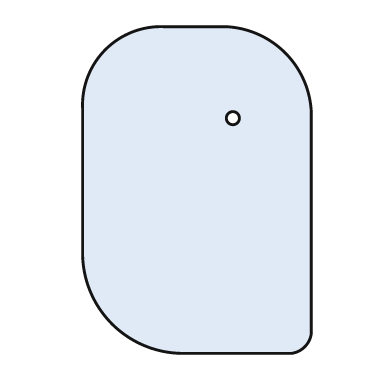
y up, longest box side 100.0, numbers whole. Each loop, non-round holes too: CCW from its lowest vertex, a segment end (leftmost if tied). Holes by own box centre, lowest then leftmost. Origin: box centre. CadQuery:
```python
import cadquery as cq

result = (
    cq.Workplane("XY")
    .moveTo(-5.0, -50.0)
    .lineTo(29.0, -50.0)
    .threePointArc((33.0, -48.0), (35.0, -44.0))
    .lineTo(35.0, 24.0)
    .threePointArc((27.0, 42.0), (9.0, 50.0))
    .lineTo(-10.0, 50.0)
    .threePointArc((-28.0, 43.0), (-35.0, 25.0))
    .lineTo(-35.0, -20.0)
    .threePointArc((-26.0, -41.0), (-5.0, -50.0))
    .close()
    .moveTo(11.0, 22.0)
    .circle(2.0)
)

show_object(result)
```